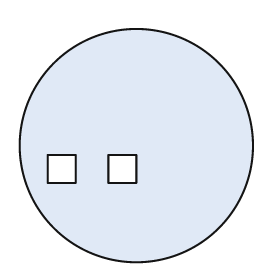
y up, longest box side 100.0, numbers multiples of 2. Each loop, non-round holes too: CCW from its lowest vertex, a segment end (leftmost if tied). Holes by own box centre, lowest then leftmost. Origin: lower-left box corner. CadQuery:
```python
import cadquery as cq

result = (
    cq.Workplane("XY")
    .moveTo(50.0, 50.0)
    .circle(50.0)
    .moveTo(12.0, 34.0)
    .lineTo(24.0, 34.0)
    .lineTo(24.0, 46.0)
    .lineTo(12.0, 46.0)
    .close()
    .moveTo(38.0, 34.0)
    .lineTo(50.0, 34.0)
    .lineTo(50.0, 46.0)
    .lineTo(38.0, 46.0)
    .close()
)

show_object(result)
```